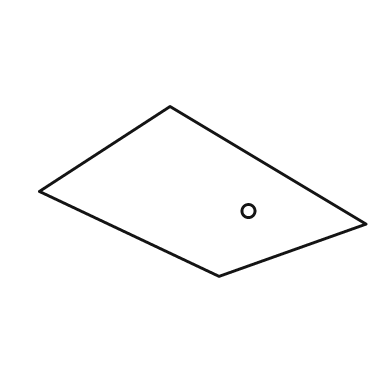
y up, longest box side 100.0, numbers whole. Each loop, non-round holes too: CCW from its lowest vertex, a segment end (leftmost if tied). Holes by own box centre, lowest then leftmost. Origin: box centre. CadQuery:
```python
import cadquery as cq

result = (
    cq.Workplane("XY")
    .moveTo(5.0, -26.0)
    .lineTo(50.0, -10.0)
    .lineTo(-10.0, 26.0)
    .lineTo(-50.0, 0.0)
    .close()
    .moveTo(14.0, -6.0)
    .circle(2.0)
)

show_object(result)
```